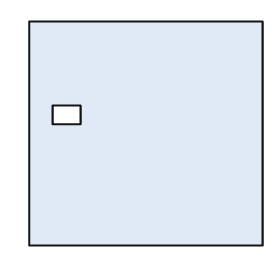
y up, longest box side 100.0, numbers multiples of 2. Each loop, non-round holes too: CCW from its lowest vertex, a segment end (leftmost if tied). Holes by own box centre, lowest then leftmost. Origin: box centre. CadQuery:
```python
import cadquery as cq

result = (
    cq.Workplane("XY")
    .moveTo(-50.0, -48.0)
    .lineTo(50.0, -48.0)
    .lineTo(50.0, 48.0)
    .lineTo(-50.0, 48.0)
    .close()
    .moveTo(-40.0, 4.0)
    .lineTo(-28.0, 4.0)
    .lineTo(-28.0, 12.0)
    .lineTo(-40.0, 12.0)
    .close()
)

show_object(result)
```